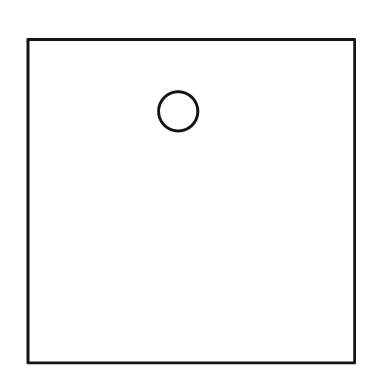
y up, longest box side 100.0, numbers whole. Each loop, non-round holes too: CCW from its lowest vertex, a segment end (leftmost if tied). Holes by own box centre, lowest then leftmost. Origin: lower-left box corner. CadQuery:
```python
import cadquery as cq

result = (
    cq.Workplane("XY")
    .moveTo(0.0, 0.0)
    .lineTo(100.0, 0.0)
    .lineTo(100.0, 99.0)
    .lineTo(0.0, 99.0)
    .close()
    .moveTo(46.0, 77.0)
    .circle(6.0)
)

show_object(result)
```